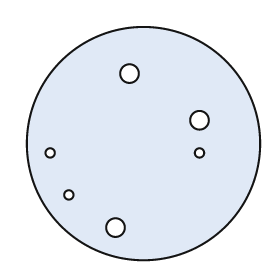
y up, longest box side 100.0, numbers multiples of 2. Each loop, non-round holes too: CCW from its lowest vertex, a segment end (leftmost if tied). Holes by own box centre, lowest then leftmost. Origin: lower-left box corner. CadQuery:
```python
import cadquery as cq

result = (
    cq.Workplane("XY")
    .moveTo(50.0, 50.0)
    .circle(50.0)
    .moveTo(38.0, 14.0)
    .circle(4.0)
    .moveTo(18.0, 28.0)
    .circle(2.0)
    .moveTo(10.0, 46.0)
    .circle(2.0)
    .moveTo(74.0, 46.0)
    .circle(2.0)
    .moveTo(74.0, 60.0)
    .circle(4.0)
    .moveTo(44.0, 80.0)
    .circle(4.0)
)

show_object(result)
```